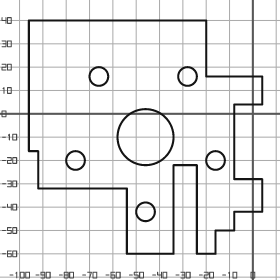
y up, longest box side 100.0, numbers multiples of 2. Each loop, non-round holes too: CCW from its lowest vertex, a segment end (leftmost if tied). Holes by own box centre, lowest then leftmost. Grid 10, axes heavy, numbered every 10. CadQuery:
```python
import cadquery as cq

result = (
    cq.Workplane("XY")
    .moveTo(-54.0, -60.0)
    .lineTo(-34.0, -60.0)
    .lineTo(-34.0, -22.0)
    .lineTo(-24.0, -22.0)
    .lineTo(-24.0, -60.0)
    .lineTo(-16.0, -60.0)
    .lineTo(-16.0, -50.0)
    .lineTo(-8.0, -50.0)
    .lineTo(-8.0, -42.0)
    .lineTo(4.0, -42.0)
    .lineTo(4.0, -28.0)
    .lineTo(-8.0, -28.0)
    .lineTo(-8.0, 4.0)
    .lineTo(4.0, 4.0)
    .lineTo(4.0, 16.0)
    .lineTo(-20.0, 16.0)
    .lineTo(-20.0, 40.0)
    .lineTo(-96.0, 40.0)
    .lineTo(-96.0, -16.0)
    .lineTo(-92.0, -16.0)
    .lineTo(-92.0, -32.0)
    .lineTo(-54.0, -32.0)
    .close()
    .moveTo(-46.0, -42.0)
    .circle(4.0)
    .moveTo(-76.0, -20.0)
    .circle(4.0)
    .moveTo(-16.0, -20.0)
    .circle(4.0)
    .moveTo(-46.0, -10.0)
    .circle(12.0)
    .moveTo(-66.0, 16.0)
    .circle(4.0)
    .moveTo(-28.0, 16.0)
    .circle(4.0)
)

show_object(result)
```